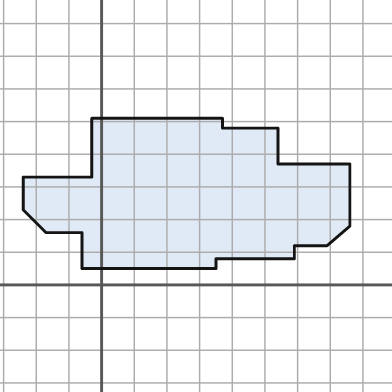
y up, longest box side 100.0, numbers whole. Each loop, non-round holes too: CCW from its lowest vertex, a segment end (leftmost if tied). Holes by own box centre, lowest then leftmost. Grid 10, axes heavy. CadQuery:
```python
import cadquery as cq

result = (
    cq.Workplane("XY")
    .moveTo(-6.0, 5.0)
    .lineTo(35.0, 5.0)
    .lineTo(35.0, 8.0)
    .lineTo(59.0, 8.0)
    .lineTo(59.0, 12.0)
    .lineTo(69.0, 12.0)
    .lineTo(76.0, 18.0)
    .lineTo(76.0, 37.0)
    .lineTo(54.0, 37.0)
    .lineTo(54.0, 48.0)
    .lineTo(37.0, 48.0)
    .lineTo(37.0, 51.0)
    .lineTo(-3.0, 51.0)
    .lineTo(-3.0, 33.0)
    .lineTo(-24.0, 33.0)
    .lineTo(-24.0, 23.0)
    .lineTo(-17.0, 16.0)
    .lineTo(-6.0, 16.0)
    .close()
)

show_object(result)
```